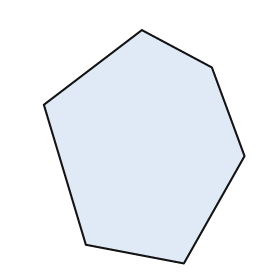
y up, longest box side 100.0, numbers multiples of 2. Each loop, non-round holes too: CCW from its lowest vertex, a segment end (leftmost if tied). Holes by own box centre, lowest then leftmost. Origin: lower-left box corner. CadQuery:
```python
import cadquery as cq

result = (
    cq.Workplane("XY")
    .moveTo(60.0, 0.0)
    .lineTo(86.0, 46.0)
    .lineTo(72.0, 84.0)
    .lineTo(42.0, 100.0)
    .lineTo(0.0, 68.0)
    .lineTo(18.0, 8.0)
    .close()
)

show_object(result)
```